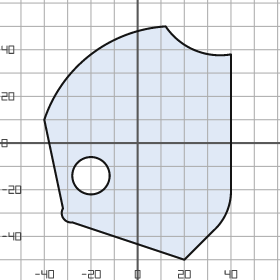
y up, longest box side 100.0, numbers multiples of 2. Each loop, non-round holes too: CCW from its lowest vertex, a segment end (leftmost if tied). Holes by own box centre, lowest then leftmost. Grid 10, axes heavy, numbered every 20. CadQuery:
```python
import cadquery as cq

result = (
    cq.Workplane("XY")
    .moveTo(20.0, -50.0)
    .lineTo(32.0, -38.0)
    .threePointArc((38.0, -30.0), (40.0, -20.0))
    .lineTo(40.0, 38.0)
    .threePointArc((24.0, 40.0), (12.0, 50.0))
    .threePointArc((-20.0, 38.0), (-40.0, 10.0))
    .lineTo(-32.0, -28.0)
    .threePointArc((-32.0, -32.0), (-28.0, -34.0))
    .close()
    .moveTo(-20.0, -14.0)
    .circle(8.0)
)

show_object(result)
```